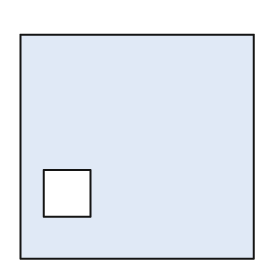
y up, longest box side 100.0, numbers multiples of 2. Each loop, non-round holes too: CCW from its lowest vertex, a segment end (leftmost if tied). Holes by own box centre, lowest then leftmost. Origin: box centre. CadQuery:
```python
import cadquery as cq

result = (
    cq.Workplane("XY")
    .moveTo(-50.0, -48.0)
    .lineTo(50.0, -48.0)
    .lineTo(50.0, 48.0)
    .lineTo(-50.0, 48.0)
    .close()
    .moveTo(-40.0, -30.0)
    .lineTo(-20.0, -30.0)
    .lineTo(-20.0, -10.0)
    .lineTo(-40.0, -10.0)
    .close()
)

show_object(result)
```